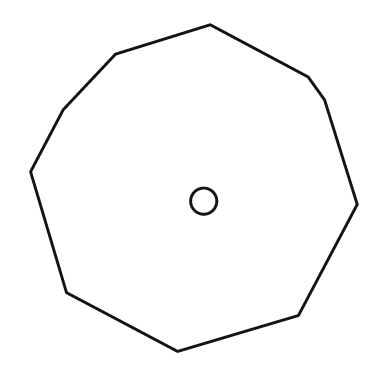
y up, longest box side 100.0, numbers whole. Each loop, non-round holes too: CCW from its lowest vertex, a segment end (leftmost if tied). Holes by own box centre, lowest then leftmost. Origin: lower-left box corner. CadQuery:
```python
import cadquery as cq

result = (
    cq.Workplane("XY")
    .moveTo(45.0, 0.0)
    .lineTo(82.0, 11.0)
    .lineTo(100.0, 45.0)
    .lineTo(90.0, 77.0)
    .lineTo(85.0, 84.0)
    .lineTo(55.0, 100.0)
    .lineTo(26.0, 91.0)
    .lineTo(10.0, 74.0)
    .lineTo(0.0, 55.0)
    .lineTo(11.0, 18.0)
    .close()
    .moveTo(53.0, 46.0)
    .circle(4.0)
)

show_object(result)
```